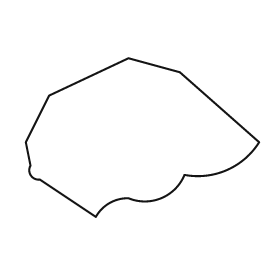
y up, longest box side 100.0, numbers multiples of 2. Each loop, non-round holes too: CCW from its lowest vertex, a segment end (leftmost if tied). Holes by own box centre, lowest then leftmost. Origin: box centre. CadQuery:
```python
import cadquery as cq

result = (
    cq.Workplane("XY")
    .moveTo(-20.0, -34.0)
    .threePointArc((-14.0, -28.0), (-6.0, -26.0))
    .threePointArc((8.0, -26.0), (18.0, -16.0))
    .threePointArc((36.0, -14.0), (50.0, -2.0))
    .lineTo(16.0, 28.0)
    .lineTo(-6.0, 34.0)
    .lineTo(-40.0, 18.0)
    .lineTo(-50.0, -2.0)
    .lineTo(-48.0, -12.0)
    .threePointArc((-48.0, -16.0), (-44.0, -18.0))
    .close()
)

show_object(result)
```